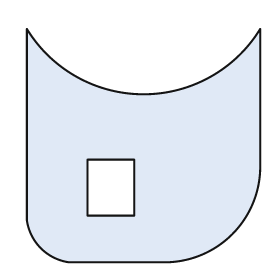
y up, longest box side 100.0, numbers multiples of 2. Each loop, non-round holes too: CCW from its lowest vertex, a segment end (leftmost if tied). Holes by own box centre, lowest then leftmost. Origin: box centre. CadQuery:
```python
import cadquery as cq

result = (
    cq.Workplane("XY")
    .moveTo(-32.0, -50.0)
    .lineTo(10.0, -50.0)
    .threePointArc((38.0, -38.0), (50.0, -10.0))
    .lineTo(50.0, 50.0)
    .threePointArc((0.0, 22.0), (-50.0, 50.0))
    .lineTo(-50.0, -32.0)
    .threePointArc((-44.0, -44.0), (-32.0, -50.0))
    .close()
    .moveTo(-24.0, -30.0)
    .lineTo(-4.0, -30.0)
    .lineTo(-4.0, -6.0)
    .lineTo(-24.0, -6.0)
    .close()
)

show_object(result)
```